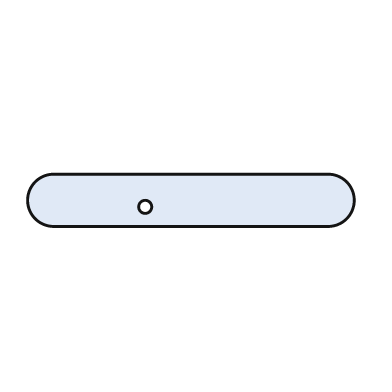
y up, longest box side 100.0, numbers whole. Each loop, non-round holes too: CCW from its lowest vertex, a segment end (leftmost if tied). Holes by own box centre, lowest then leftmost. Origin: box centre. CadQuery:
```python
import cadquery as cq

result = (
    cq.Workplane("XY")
    .moveTo(-42.0, -8.0)
    .lineTo(42.0, -8.0)
    .threePointArc((50.0, 0.0), (42.0, 8.0))
    .lineTo(-42.0, 8.0)
    .threePointArc((-50.0, 0.0), (-42.0, -8.0))
    .close()
    .moveTo(-14.0, -2.0)
    .circle(2.0)
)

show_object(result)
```